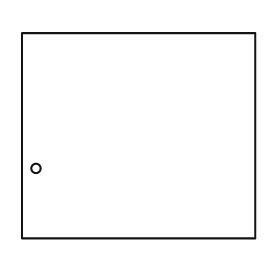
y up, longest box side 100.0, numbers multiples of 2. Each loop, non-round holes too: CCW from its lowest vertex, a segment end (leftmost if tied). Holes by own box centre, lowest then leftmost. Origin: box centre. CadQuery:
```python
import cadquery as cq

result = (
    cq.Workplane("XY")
    .moveTo(-50.0, -44.0)
    .lineTo(50.0, -44.0)
    .lineTo(50.0, 44.0)
    .lineTo(-50.0, 44.0)
    .close()
    .moveTo(-44.0, -14.0)
    .circle(2.0)
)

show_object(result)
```